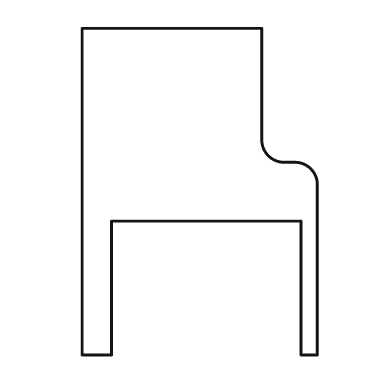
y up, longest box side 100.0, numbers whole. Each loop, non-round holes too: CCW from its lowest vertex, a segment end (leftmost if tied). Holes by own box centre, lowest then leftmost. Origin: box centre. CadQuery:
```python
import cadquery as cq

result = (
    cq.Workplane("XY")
    .moveTo(-36.0, -50.0)
    .lineTo(-27.0, -50.0)
    .lineTo(-27.0, -9.0)
    .lineTo(31.0, -9.0)
    .lineTo(31.0, -50.0)
    .lineTo(36.0, -50.0)
    .lineTo(36.0, 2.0)
    .threePointArc((34.0, 7.0), (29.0, 9.0))
    .lineTo(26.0, 9.0)
    .threePointArc((21.0, 11.0), (19.0, 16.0))
    .lineTo(19.0, 50.0)
    .lineTo(-36.0, 50.0)
    .close()
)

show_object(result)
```